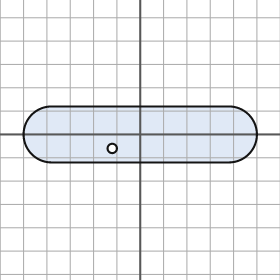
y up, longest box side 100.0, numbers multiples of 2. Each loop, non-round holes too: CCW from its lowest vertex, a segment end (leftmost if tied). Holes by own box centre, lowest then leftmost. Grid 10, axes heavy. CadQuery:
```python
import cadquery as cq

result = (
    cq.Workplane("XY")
    .moveTo(-38.0, -12.0)
    .lineTo(38.0, -12.0)
    .threePointArc((50.0, 0.0), (38.0, 12.0))
    .lineTo(-38.0, 12.0)
    .threePointArc((-50.0, 0.0), (-38.0, -12.0))
    .close()
    .moveTo(-12.0, -6.0)
    .circle(2.0)
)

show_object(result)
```